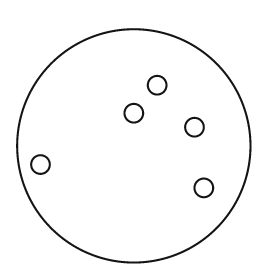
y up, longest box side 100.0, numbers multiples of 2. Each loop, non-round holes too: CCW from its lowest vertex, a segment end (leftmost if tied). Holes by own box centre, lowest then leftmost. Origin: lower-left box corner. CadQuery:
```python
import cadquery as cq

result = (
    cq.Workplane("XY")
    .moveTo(50.0, 50.0)
    .circle(50.0)
    .moveTo(80.0, 32.0)
    .circle(4.0)
    .moveTo(10.0, 42.0)
    .circle(4.0)
    .moveTo(76.0, 58.0)
    .circle(4.0)
    .moveTo(50.0, 64.0)
    .circle(4.0)
    .moveTo(60.0, 76.0)
    .circle(4.0)
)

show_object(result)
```